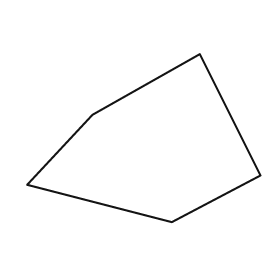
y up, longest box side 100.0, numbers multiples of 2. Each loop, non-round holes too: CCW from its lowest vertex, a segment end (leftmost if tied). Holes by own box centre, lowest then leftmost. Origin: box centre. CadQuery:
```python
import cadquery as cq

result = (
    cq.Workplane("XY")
    .moveTo(12.0, -36.0)
    .lineTo(50.0, -16.0)
    .lineTo(24.0, 36.0)
    .lineTo(-22.0, 10.0)
    .lineTo(-50.0, -20.0)
    .close()
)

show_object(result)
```